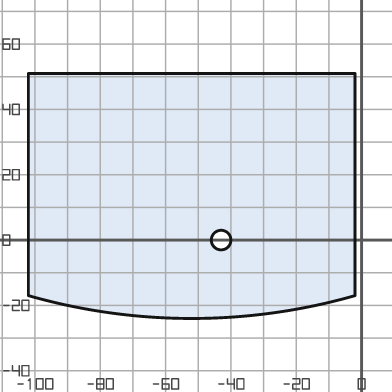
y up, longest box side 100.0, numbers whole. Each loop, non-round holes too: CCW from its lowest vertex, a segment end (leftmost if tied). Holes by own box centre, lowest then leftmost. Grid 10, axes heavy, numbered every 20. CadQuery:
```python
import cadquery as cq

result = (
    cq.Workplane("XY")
    .moveTo(-102.0, -17.0)
    .threePointArc((-52.0, -24.0), (-2.0, -17.0))
    .lineTo(-2.0, 51.0)
    .lineTo(-102.0, 51.0)
    .close()
    .moveTo(-43.0, 0.0)
    .circle(3.0)
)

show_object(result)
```